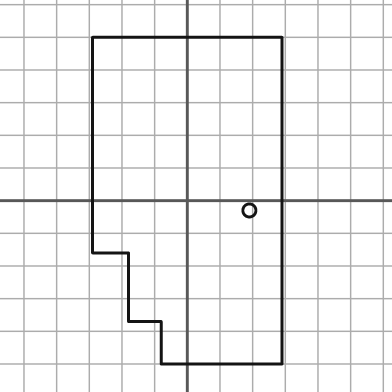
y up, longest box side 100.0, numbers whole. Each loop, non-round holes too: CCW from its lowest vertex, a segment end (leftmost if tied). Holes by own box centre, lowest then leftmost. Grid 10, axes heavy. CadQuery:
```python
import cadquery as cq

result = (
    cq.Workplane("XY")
    .moveTo(-8.0, -50.0)
    .lineTo(29.0, -50.0)
    .lineTo(29.0, 50.0)
    .lineTo(-29.0, 50.0)
    .lineTo(-29.0, -16.0)
    .lineTo(-18.0, -16.0)
    .lineTo(-18.0, -37.0)
    .lineTo(-8.0, -37.0)
    .close()
    .moveTo(19.0, -3.0)
    .circle(2.0)
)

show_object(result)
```